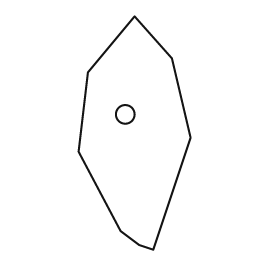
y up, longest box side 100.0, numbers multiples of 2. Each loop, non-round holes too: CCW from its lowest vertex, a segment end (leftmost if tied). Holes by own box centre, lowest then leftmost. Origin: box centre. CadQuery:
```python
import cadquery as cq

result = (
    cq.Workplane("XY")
    .moveTo(8.0, -50.0)
    .lineTo(24.0, -2.0)
    .lineTo(16.0, 32.0)
    .lineTo(0.0, 50.0)
    .lineTo(-20.0, 26.0)
    .lineTo(-24.0, -8.0)
    .lineTo(-6.0, -42.0)
    .lineTo(2.0, -48.0)
    .close()
    .moveTo(-4.0, 8.0)
    .circle(4.0)
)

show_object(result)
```